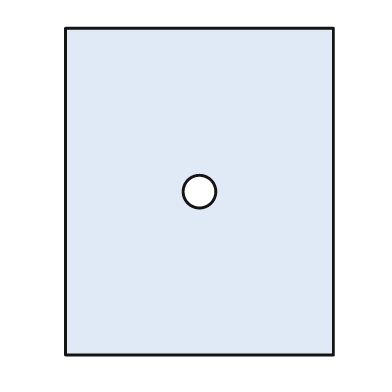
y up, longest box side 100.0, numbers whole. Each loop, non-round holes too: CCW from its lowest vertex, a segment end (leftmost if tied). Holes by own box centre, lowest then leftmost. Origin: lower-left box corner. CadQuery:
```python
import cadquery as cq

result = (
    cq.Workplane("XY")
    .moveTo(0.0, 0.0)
    .lineTo(82.0, 0.0)
    .lineTo(82.0, 100.0)
    .lineTo(0.0, 100.0)
    .close()
    .moveTo(41.0, 50.0)
    .circle(5.0)
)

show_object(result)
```